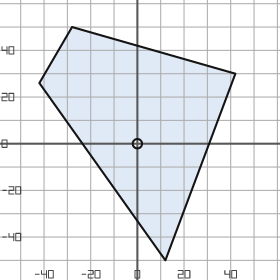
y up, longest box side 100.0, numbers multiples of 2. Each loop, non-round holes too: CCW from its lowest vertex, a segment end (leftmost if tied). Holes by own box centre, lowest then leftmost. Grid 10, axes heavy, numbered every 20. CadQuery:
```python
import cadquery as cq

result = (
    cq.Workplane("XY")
    .moveTo(12.0, -50.0)
    .lineTo(42.0, 30.0)
    .lineTo(-28.0, 50.0)
    .lineTo(-42.0, 26.0)
    .close()
    .moveTo(0.0, 0.0)
    .circle(2.0)
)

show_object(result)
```